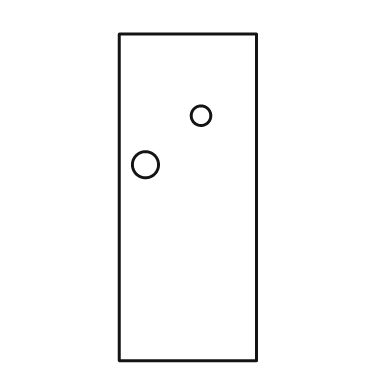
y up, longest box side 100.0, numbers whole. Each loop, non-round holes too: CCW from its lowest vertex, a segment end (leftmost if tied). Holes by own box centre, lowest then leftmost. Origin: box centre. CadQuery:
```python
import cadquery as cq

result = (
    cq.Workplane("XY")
    .moveTo(-21.0, -50.0)
    .lineTo(21.0, -50.0)
    .lineTo(21.0, 50.0)
    .lineTo(-21.0, 50.0)
    .close()
    .moveTo(-13.0, 10.0)
    .circle(4.0)
    .moveTo(4.0, 25.0)
    .circle(3.0)
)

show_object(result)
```